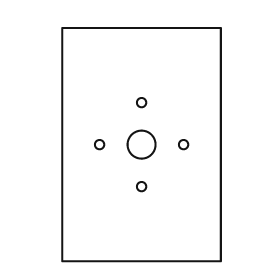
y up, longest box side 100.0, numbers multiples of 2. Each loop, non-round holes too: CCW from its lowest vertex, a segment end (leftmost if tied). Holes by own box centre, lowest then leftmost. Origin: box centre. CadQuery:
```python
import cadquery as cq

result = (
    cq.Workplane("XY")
    .moveTo(-34.0, -50.0)
    .lineTo(34.0, -50.0)
    .lineTo(34.0, 50.0)
    .lineTo(-34.0, 50.0)
    .close()
    .moveTo(0.0, -18.0)
    .circle(2.0)
    .moveTo(-18.0, 0.0)
    .circle(2.0)
    .moveTo(0.0, 0.0)
    .circle(6.0)
    .moveTo(18.0, 0.0)
    .circle(2.0)
    .moveTo(0.0, 18.0)
    .circle(2.0)
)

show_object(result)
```